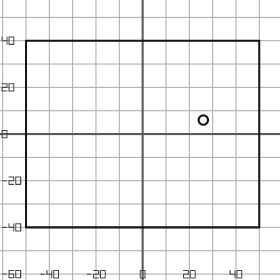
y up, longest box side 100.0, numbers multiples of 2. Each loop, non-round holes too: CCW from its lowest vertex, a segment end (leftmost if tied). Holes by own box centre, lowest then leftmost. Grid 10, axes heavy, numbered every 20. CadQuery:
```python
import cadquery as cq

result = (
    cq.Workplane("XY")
    .moveTo(-50.0, -40.0)
    .lineTo(50.0, -40.0)
    .lineTo(50.0, 40.0)
    .lineTo(-50.0, 40.0)
    .close()
    .moveTo(26.0, 6.0)
    .circle(2.0)
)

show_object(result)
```